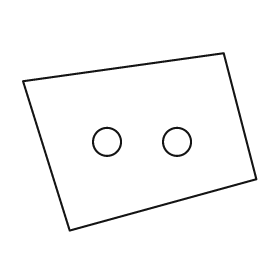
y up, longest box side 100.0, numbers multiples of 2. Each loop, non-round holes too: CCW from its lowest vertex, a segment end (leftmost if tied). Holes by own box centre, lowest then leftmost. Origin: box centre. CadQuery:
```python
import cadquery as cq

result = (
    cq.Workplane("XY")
    .moveTo(-30.0, -38.0)
    .lineTo(50.0, -16.0)
    .lineTo(36.0, 38.0)
    .lineTo(-50.0, 26.0)
    .close()
    .moveTo(-14.0, 0.0)
    .circle(6.0)
    .moveTo(16.0, 0.0)
    .circle(6.0)
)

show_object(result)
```